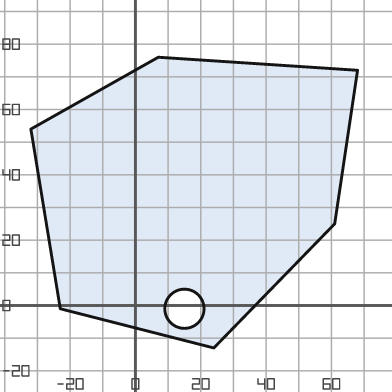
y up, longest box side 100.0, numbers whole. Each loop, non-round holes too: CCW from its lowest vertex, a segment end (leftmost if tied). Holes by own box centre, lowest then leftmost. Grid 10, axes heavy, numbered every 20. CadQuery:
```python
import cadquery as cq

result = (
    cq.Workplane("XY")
    .moveTo(24.0, -13.0)
    .lineTo(61.0, 25.0)
    .lineTo(68.0, 72.0)
    .lineTo(7.0, 76.0)
    .lineTo(-32.0, 54.0)
    .lineTo(-23.0, -1.0)
    .close()
    .moveTo(15.0, -1.0)
    .circle(6.0)
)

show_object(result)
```